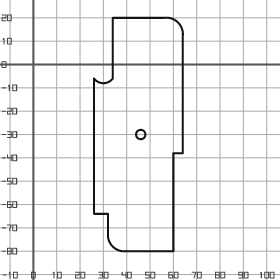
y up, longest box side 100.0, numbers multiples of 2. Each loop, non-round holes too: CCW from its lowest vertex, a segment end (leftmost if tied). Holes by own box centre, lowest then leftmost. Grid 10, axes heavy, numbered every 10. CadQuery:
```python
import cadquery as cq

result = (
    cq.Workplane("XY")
    .moveTo(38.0, -80.0)
    .lineTo(60.0, -80.0)
    .lineTo(60.0, -38.0)
    .lineTo(64.0, -38.0)
    .lineTo(64.0, 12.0)
    .threePointArc((62.0, 18.0), (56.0, 20.0))
    .lineTo(34.0, 20.0)
    .lineTo(34.0, -6.0)
    .threePointArc((30.0, -8.0), (26.0, -6.0))
    .lineTo(26.0, -64.0)
    .lineTo(32.0, -64.0)
    .lineTo(32.0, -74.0)
    .threePointArc((34.0, -78.0), (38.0, -80.0))
    .close()
    .moveTo(46.0, -30.0)
    .circle(2.0)
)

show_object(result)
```